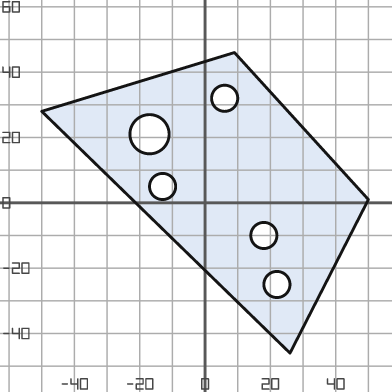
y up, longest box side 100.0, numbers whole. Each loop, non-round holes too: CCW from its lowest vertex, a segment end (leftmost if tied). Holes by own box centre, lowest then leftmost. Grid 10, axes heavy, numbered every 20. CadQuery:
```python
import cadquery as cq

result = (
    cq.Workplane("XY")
    .moveTo(26.0, -46.0)
    .lineTo(50.0, 1.0)
    .lineTo(9.0, 46.0)
    .lineTo(-50.0, 28.0)
    .close()
    .moveTo(22.0, -25.0)
    .circle(4.0)
    .moveTo(18.0, -10.0)
    .circle(4.0)
    .moveTo(-13.0, 5.0)
    .circle(4.0)
    .moveTo(-17.0, 21.0)
    .circle(6.0)
    .moveTo(6.0, 32.0)
    .circle(4.0)
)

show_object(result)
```